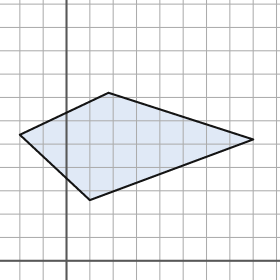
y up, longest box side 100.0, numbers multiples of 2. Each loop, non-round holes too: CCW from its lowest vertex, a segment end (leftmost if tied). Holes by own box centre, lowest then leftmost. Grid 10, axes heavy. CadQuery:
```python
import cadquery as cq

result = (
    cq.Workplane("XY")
    .moveTo(10.0, 26.0)
    .lineTo(80.0, 52.0)
    .lineTo(18.0, 72.0)
    .lineTo(-20.0, 54.0)
    .close()
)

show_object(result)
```